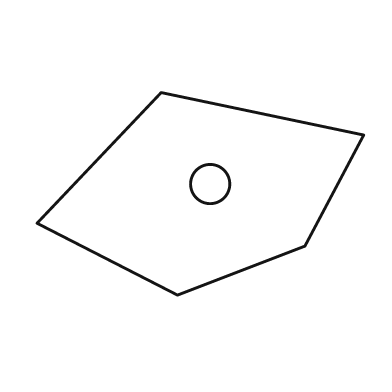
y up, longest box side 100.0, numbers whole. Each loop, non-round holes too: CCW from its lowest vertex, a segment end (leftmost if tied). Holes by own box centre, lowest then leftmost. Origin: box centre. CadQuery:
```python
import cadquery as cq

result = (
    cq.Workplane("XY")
    .moveTo(-7.0, -31.0)
    .lineTo(32.0, -16.0)
    .lineTo(50.0, 18.0)
    .lineTo(-12.0, 31.0)
    .lineTo(-50.0, -9.0)
    .close()
    .moveTo(3.0, 3.0)
    .circle(6.0)
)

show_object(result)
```